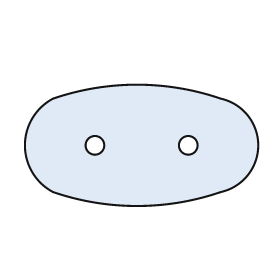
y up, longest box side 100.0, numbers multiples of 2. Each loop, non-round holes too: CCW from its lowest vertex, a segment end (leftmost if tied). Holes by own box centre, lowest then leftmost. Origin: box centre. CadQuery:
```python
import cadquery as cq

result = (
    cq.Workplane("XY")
    .moveTo(-38.0, -20.0)
    .threePointArc((-2.0, -26.0), (34.0, -20.0))
    .threePointArc((50.0, 0.0), (34.0, 20.0))
    .threePointArc((-2.0, 26.0), (-38.0, 20.0))
    .threePointArc((-50.0, 0.0), (-38.0, -20.0))
    .close()
    .moveTo(-20.0, 0.0)
    .circle(4.0)
    .moveTo(20.0, 0.0)
    .circle(4.0)
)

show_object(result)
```